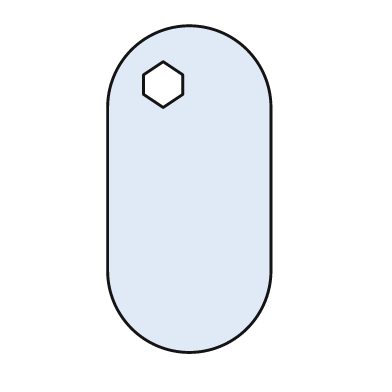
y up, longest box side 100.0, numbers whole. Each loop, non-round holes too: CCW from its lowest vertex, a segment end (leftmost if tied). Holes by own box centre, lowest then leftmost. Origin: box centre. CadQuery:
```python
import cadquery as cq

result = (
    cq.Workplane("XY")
    .moveTo(-25.0, -25.0)
    .threePointArc((0.0, -50.0), (25.0, -25.0))
    .lineTo(25.0, 25.0)
    .threePointArc((0.0, 50.0), (-25.0, 25.0))
    .close()
    .moveTo(-8.0, 25.0)
    .lineTo(-2.0, 29.0)
    .lineTo(-2.0, 35.0)
    .lineTo(-8.0, 39.0)
    .lineTo(-14.0, 35.0)
    .lineTo(-14.0, 29.0)
    .close()
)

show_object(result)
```